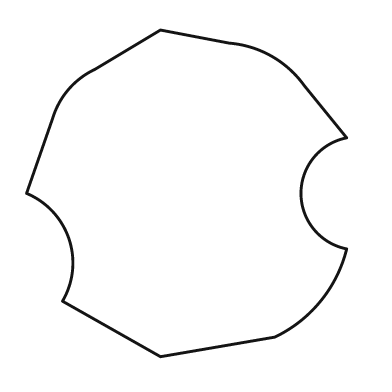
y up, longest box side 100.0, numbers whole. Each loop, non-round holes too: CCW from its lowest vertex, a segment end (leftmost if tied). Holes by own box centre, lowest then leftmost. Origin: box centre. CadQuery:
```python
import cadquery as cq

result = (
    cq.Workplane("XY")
    .moveTo(-8.0, -50.0)
    .lineTo(27.0, -44.0)
    .threePointArc((41.0, -33.0), (49.0, -17.0))
    .threePointArc((35.0, 0.0), (49.0, 17.0))
    .lineTo(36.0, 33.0)
    .threePointArc((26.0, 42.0), (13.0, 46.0))
    .lineTo(-8.0, 50.0)
    .lineTo(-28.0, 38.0)
    .threePointArc((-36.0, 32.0), (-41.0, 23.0))
    .lineTo(-49.0, 0.0)
    .threePointArc((-36.0, -14.0), (-38.0, -33.0))
    .close()
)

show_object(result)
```